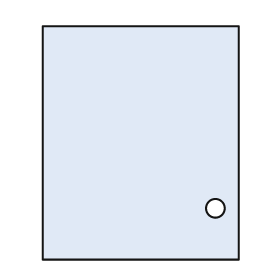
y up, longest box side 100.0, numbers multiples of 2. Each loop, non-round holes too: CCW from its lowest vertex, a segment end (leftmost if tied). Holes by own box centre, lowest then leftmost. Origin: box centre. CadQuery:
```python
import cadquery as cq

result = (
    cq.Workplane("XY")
    .moveTo(-42.0, -50.0)
    .lineTo(42.0, -50.0)
    .lineTo(42.0, 50.0)
    .lineTo(-42.0, 50.0)
    .close()
    .moveTo(32.0, -28.0)
    .circle(4.0)
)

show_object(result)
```